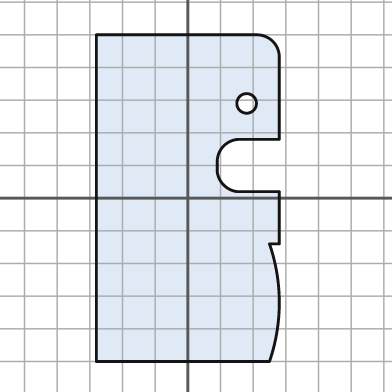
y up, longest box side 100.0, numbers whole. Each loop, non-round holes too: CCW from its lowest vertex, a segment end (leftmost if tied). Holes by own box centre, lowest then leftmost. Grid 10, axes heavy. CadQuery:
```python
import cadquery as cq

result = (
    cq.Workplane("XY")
    .moveTo(-28.0, -50.0)
    .lineTo(25.0, -50.0)
    .threePointArc((28.0, -32.0), (25.0, -14.0))
    .lineTo(28.0, -14.0)
    .lineTo(28.0, 2.0)
    .lineTo(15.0, 2.0)
    .threePointArc((11.0, 4.0), (9.0, 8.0))
    .lineTo(9.0, 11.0)
    .threePointArc((11.0, 16.0), (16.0, 18.0))
    .lineTo(28.0, 18.0)
    .lineTo(28.0, 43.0)
    .threePointArc((26.0, 48.0), (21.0, 50.0))
    .lineTo(-28.0, 50.0)
    .close()
    .moveTo(18.0, 29.0)
    .circle(3.0)
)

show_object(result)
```